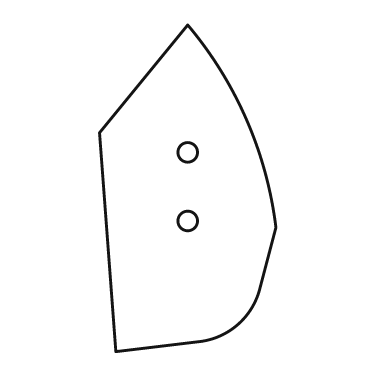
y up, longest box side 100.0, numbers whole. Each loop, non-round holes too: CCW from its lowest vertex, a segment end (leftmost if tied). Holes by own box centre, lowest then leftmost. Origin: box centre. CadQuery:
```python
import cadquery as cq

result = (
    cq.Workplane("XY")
    .moveTo(-22.0, -50.0)
    .lineTo(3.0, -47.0)
    .threePointArc((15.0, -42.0), (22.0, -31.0))
    .lineTo(27.0, -12.0)
    .threePointArc((18.0, 21.0), (0.0, 50.0))
    .lineTo(-27.0, 17.0)
    .close()
    .moveTo(0.0, -10.0)
    .circle(3.0)
    .moveTo(0.0, 11.0)
    .circle(3.0)
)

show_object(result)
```